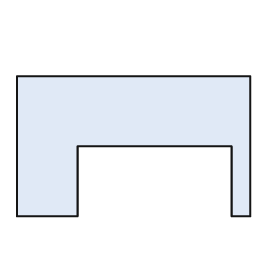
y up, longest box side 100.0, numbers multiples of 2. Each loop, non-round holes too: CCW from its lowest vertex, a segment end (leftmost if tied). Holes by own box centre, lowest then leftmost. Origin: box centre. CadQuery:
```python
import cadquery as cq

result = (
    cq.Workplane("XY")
    .moveTo(-50.0, -30.0)
    .lineTo(-24.0, -30.0)
    .lineTo(-24.0, 0.0)
    .lineTo(42.0, 0.0)
    .lineTo(42.0, -30.0)
    .lineTo(50.0, -30.0)
    .lineTo(50.0, 30.0)
    .lineTo(-50.0, 30.0)
    .close()
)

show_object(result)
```